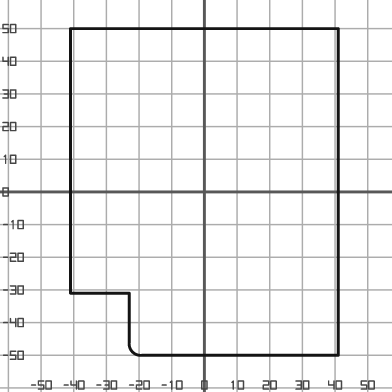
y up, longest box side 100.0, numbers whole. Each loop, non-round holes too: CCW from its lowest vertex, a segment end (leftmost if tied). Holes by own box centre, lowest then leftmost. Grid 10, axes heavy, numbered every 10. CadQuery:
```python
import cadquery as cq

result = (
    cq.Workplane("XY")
    .moveTo(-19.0, -50.0)
    .lineTo(41.0, -50.0)
    .lineTo(41.0, 50.0)
    .lineTo(-41.0, 50.0)
    .lineTo(-41.0, -31.0)
    .lineTo(-23.0, -31.0)
    .lineTo(-23.0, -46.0)
    .threePointArc((-22.0, -49.0), (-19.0, -50.0))
    .close()
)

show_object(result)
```